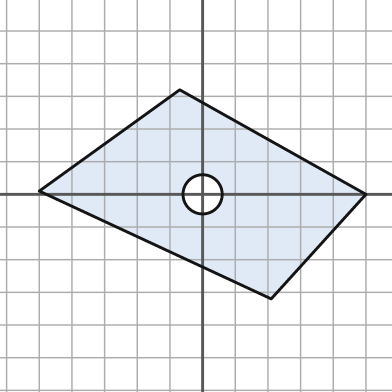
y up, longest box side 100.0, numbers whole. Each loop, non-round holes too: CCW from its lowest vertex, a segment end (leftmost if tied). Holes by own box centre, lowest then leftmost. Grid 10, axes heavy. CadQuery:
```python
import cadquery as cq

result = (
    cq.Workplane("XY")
    .moveTo(21.0, -32.0)
    .lineTo(50.0, 0.0)
    .lineTo(-7.0, 32.0)
    .lineTo(-50.0, 1.0)
    .close()
    .moveTo(0.0, 0.0)
    .circle(6.0)
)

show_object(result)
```